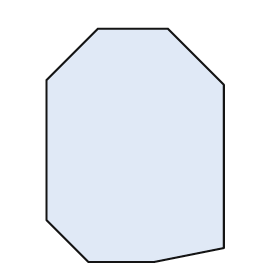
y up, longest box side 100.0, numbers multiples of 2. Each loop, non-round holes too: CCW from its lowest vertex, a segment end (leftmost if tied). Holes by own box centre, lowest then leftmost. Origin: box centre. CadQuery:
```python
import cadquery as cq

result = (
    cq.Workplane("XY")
    .moveTo(-20.0, -50.0)
    .lineTo(8.0, -50.0)
    .lineTo(38.0, -44.0)
    .lineTo(38.0, 26.0)
    .lineTo(14.0, 50.0)
    .lineTo(-16.0, 50.0)
    .lineTo(-38.0, 28.0)
    .lineTo(-38.0, -32.0)
    .close()
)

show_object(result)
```